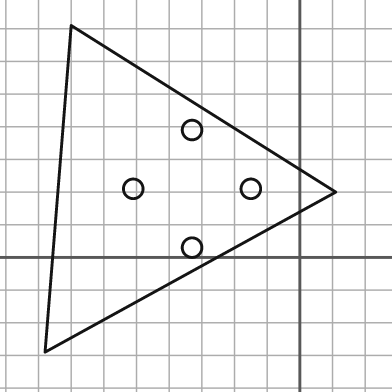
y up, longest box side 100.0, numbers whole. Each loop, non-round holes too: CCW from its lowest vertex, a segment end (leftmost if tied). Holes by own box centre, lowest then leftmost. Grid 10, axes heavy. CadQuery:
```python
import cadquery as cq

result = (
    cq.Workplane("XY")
    .moveTo(-78.0, -29.0)
    .lineTo(11.0, 20.0)
    .lineTo(-70.0, 71.0)
    .close()
    .moveTo(-33.0, 3.0)
    .circle(3.0)
    .moveTo(-51.0, 21.0)
    .circle(3.0)
    .moveTo(-15.0, 21.0)
    .circle(3.0)
    .moveTo(-33.0, 39.0)
    .circle(3.0)
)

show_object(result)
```